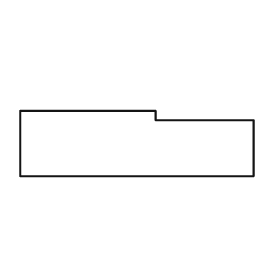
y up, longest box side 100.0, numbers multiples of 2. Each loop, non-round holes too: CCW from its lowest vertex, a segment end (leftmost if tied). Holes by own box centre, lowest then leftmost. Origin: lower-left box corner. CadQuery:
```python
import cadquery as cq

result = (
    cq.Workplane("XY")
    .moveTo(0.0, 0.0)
    .lineTo(100.0, 0.0)
    .lineTo(100.0, 24.0)
    .lineTo(58.0, 24.0)
    .lineTo(58.0, 28.0)
    .lineTo(0.0, 28.0)
    .close()
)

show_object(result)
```